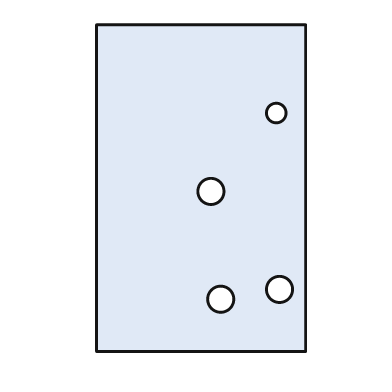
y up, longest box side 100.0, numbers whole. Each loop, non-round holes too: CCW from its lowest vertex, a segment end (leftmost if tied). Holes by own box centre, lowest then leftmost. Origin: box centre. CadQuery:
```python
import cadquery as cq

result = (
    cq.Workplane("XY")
    .moveTo(-32.0, -50.0)
    .lineTo(32.0, -50.0)
    .lineTo(32.0, 50.0)
    .lineTo(-32.0, 50.0)
    .close()
    .moveTo(6.0, -34.0)
    .circle(4.0)
    .moveTo(24.0, -31.0)
    .circle(4.0)
    .moveTo(3.0, -1.0)
    .circle(4.0)
    .moveTo(23.0, 23.0)
    .circle(3.0)
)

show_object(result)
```